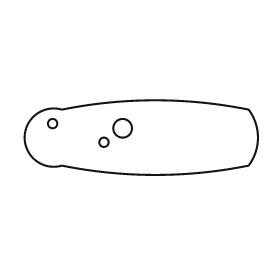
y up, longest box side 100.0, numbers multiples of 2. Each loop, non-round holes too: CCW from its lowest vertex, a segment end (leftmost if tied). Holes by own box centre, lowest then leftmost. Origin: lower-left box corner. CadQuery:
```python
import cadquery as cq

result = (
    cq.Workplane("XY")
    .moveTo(16.0, 4.0)
    .threePointArc((56.0, 0.0), (96.0, 4.0))
    .threePointArc((100.0, 16.0), (96.0, 28.0))
    .threePointArc((56.0, 32.0), (16.0, 28.0))
    .threePointArc((0.0, 16.0), (16.0, 4.0))
    .close()
    .moveTo(34.0, 14.0)
    .circle(2.0)
    .moveTo(42.0, 20.0)
    .circle(4.0)
    .moveTo(12.0, 22.0)
    .circle(2.0)
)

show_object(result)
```